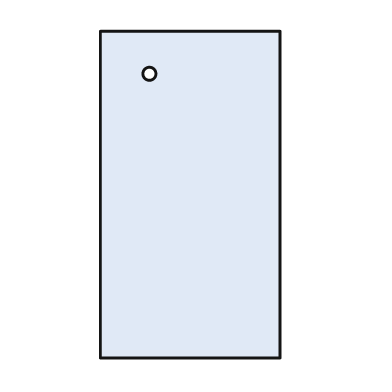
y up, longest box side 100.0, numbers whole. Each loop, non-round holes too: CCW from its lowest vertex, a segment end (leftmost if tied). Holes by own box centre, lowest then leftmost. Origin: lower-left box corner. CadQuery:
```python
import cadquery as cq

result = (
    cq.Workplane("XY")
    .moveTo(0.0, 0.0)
    .lineTo(55.0, 0.0)
    .lineTo(55.0, 100.0)
    .lineTo(0.0, 100.0)
    .close()
    .moveTo(15.0, 87.0)
    .circle(2.0)
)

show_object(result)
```